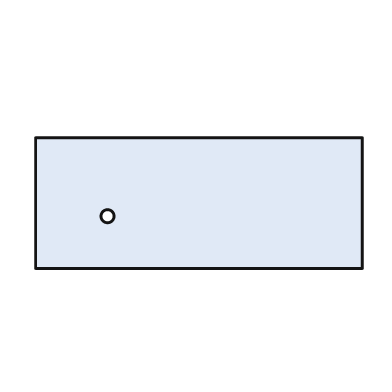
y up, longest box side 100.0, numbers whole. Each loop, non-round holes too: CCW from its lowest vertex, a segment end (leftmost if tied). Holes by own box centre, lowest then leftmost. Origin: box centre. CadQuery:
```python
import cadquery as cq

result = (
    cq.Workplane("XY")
    .moveTo(-50.0, -20.0)
    .lineTo(50.0, -20.0)
    .lineTo(50.0, 20.0)
    .lineTo(-50.0, 20.0)
    .close()
    .moveTo(-28.0, -4.0)
    .circle(2.0)
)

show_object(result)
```